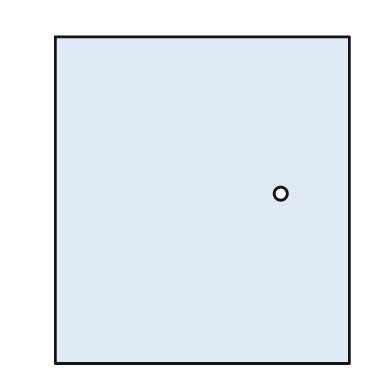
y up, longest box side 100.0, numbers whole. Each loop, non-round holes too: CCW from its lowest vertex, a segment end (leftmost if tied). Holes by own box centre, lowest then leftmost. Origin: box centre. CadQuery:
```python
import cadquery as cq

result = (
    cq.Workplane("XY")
    .moveTo(-45.0, -50.0)
    .lineTo(45.0, -50.0)
    .lineTo(45.0, 50.0)
    .lineTo(-45.0, 50.0)
    .close()
    .moveTo(24.0, 2.0)
    .circle(2.0)
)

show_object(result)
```